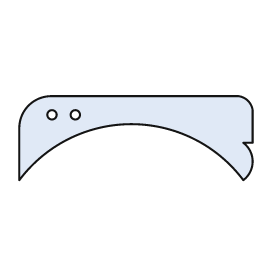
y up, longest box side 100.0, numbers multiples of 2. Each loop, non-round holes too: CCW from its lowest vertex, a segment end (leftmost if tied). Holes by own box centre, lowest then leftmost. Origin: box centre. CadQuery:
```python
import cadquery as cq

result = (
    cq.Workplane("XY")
    .moveTo(-50.0, -18.0)
    .threePointArc((-2.0, 6.0), (46.0, -18.0))
    .threePointArc((50.0, -10.0), (46.0, -2.0))
    .lineTo(50.0, -2.0)
    .lineTo(50.0, 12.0)
    .threePointArc((48.0, 16.0), (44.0, 18.0))
    .lineTo(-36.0, 18.0)
    .threePointArc((-46.0, 14.0), (-50.0, 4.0))
    .close()
    .moveTo(-36.0, 10.0)
    .circle(2.0)
    .moveTo(-26.0, 10.0)
    .circle(2.0)
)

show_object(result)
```